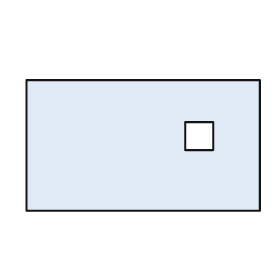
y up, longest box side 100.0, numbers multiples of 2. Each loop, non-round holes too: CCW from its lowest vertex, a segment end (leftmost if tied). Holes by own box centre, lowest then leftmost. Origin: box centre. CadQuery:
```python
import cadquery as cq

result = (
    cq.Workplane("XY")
    .moveTo(-50.0, -28.0)
    .lineTo(50.0, -28.0)
    .lineTo(50.0, 28.0)
    .lineTo(-50.0, 28.0)
    .close()
    .moveTo(18.0, -2.0)
    .lineTo(30.0, -2.0)
    .lineTo(30.0, 10.0)
    .lineTo(18.0, 10.0)
    .close()
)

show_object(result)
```